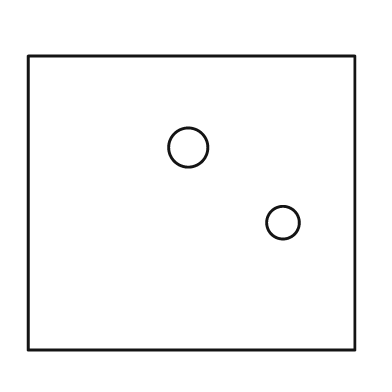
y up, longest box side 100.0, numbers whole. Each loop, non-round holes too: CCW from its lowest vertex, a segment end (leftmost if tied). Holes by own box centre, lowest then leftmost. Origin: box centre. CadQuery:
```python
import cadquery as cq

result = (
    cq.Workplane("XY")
    .moveTo(-50.0, -45.0)
    .lineTo(50.0, -45.0)
    .lineTo(50.0, 45.0)
    .lineTo(-50.0, 45.0)
    .close()
    .moveTo(28.0, -6.0)
    .circle(5.0)
    .moveTo(-1.0, 17.0)
    .circle(6.0)
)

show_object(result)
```